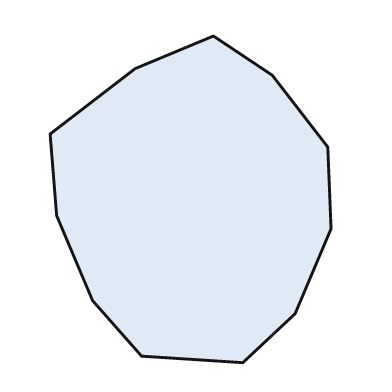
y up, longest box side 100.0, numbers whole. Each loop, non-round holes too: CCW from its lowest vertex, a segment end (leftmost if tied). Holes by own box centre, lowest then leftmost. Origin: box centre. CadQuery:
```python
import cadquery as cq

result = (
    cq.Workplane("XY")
    .moveTo(16.0, -50.0)
    .lineTo(32.0, -35.0)
    .lineTo(43.0, -9.0)
    .lineTo(42.0, 16.0)
    .lineTo(25.0, 38.0)
    .lineTo(7.0, 50.0)
    .lineTo(-17.0, 40.0)
    .lineTo(-43.0, 20.0)
    .lineTo(-41.0, -5.0)
    .lineTo(-30.0, -31.0)
    .lineTo(-15.0, -48.0)
    .close()
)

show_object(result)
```